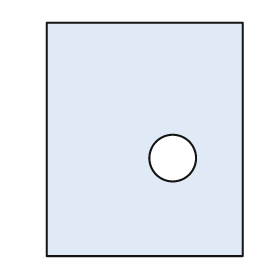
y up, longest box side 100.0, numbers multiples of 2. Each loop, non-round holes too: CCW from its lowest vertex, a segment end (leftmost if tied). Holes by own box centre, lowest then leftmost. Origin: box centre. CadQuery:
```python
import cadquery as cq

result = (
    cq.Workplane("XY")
    .moveTo(-42.0, -50.0)
    .lineTo(42.0, -50.0)
    .lineTo(42.0, 50.0)
    .lineTo(-42.0, 50.0)
    .close()
    .moveTo(12.0, -8.0)
    .circle(10.0)
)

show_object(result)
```